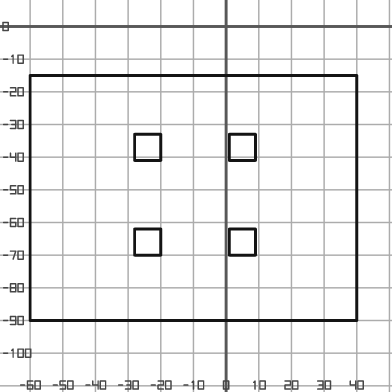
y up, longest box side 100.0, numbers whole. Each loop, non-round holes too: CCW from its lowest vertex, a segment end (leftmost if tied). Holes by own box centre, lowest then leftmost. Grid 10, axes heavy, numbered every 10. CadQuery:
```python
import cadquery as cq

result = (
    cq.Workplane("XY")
    .moveTo(-60.0, -90.0)
    .lineTo(40.0, -90.0)
    .lineTo(40.0, -15.0)
    .lineTo(-60.0, -15.0)
    .close()
    .moveTo(-28.0, -70.0)
    .lineTo(-20.0, -70.0)
    .lineTo(-20.0, -62.0)
    .lineTo(-28.0, -62.0)
    .close()
    .moveTo(1.0, -70.0)
    .lineTo(9.0, -70.0)
    .lineTo(9.0, -62.0)
    .lineTo(1.0, -62.0)
    .close()
    .moveTo(-28.0, -41.0)
    .lineTo(-20.0, -41.0)
    .lineTo(-20.0, -33.0)
    .lineTo(-28.0, -33.0)
    .close()
    .moveTo(1.0, -41.0)
    .lineTo(9.0, -41.0)
    .lineTo(9.0, -33.0)
    .lineTo(1.0, -33.0)
    .close()
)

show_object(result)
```